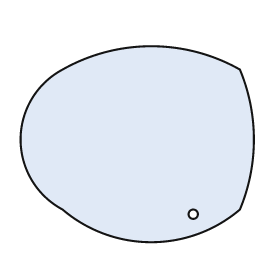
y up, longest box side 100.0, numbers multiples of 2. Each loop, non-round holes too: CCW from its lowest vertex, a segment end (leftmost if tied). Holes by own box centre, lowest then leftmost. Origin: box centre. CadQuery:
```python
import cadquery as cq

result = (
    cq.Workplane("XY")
    .moveTo(-32.0, -28.0)
    .threePointArc((6.0, -42.0), (44.0, -28.0))
    .threePointArc((50.0, 2.0), (44.0, 32.0))
    .threePointArc((6.0, 42.0), (-32.0, 32.0))
    .threePointArc((-50.0, 2.0), (-32.0, -28.0))
    .close()
    .moveTo(24.0, -30.0)
    .circle(2.0)
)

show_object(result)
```